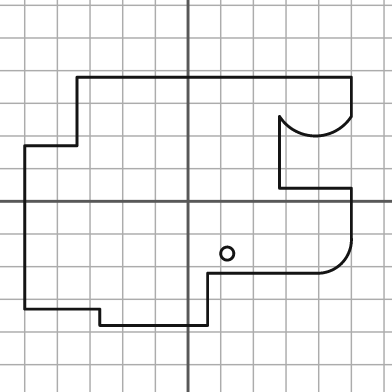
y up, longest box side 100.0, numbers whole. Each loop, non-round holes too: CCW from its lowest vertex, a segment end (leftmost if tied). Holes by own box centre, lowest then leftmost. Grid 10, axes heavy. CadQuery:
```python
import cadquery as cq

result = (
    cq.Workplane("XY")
    .moveTo(-27.0, -38.0)
    .lineTo(6.0, -38.0)
    .lineTo(6.0, -22.0)
    .lineTo(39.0, -22.0)
    .threePointArc((47.0, -19.0), (50.0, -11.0))
    .lineTo(50.0, 4.0)
    .lineTo(28.0, 4.0)
    .lineTo(28.0, 26.0)
    .threePointArc((39.0, 20.0), (50.0, 26.0))
    .lineTo(50.0, 38.0)
    .lineTo(-34.0, 38.0)
    .lineTo(-34.0, 17.0)
    .lineTo(-50.0, 17.0)
    .lineTo(-50.0, -33.0)
    .lineTo(-27.0, -33.0)
    .close()
    .moveTo(12.0, -16.0)
    .circle(2.0)
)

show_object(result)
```